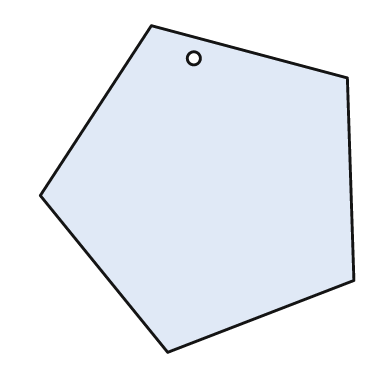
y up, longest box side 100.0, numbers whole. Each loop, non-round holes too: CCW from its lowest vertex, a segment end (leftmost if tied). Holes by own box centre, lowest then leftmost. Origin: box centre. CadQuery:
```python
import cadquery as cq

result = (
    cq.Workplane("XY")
    .moveTo(-9.0, -50.0)
    .lineTo(48.0, -28.0)
    .lineTo(46.0, 34.0)
    .lineTo(-14.0, 50.0)
    .lineTo(-48.0, -2.0)
    .close()
    .moveTo(-1.0, 40.0)
    .circle(2.0)
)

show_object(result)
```